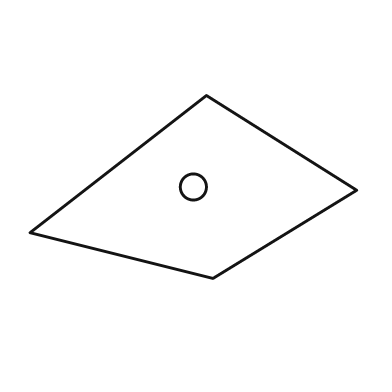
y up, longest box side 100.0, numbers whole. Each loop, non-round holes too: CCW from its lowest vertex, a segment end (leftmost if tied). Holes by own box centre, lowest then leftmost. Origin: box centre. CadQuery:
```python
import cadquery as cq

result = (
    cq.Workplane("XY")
    .moveTo(6.0, -28.0)
    .lineTo(50.0, -1.0)
    .lineTo(4.0, 28.0)
    .lineTo(-50.0, -14.0)
    .close()
    .moveTo(0.0, 0.0)
    .circle(4.0)
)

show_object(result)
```